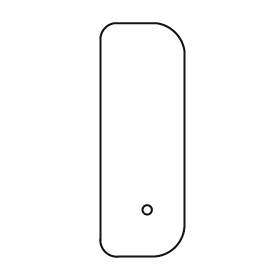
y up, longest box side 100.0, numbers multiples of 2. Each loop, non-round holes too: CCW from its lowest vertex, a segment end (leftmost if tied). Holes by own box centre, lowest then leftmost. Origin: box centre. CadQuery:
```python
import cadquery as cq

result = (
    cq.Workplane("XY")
    .moveTo(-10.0, -50.0)
    .lineTo(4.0, -50.0)
    .threePointArc((14.0, -46.0), (18.0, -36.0))
    .lineTo(18.0, 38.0)
    .threePointArc((14.0, 46.0), (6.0, 50.0))
    .lineTo(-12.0, 50.0)
    .threePointArc((-16.0, 48.0), (-18.0, 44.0))
    .lineTo(-18.0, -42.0)
    .threePointArc((-16.0, -48.0), (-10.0, -50.0))
    .close()
    .moveTo(2.0, -30.0)
    .circle(2.0)
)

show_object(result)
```